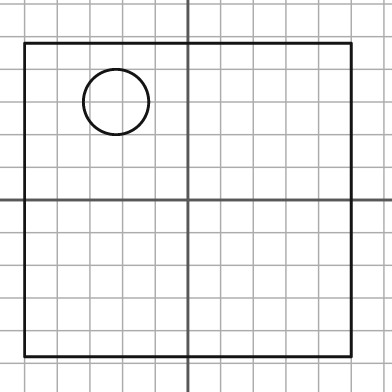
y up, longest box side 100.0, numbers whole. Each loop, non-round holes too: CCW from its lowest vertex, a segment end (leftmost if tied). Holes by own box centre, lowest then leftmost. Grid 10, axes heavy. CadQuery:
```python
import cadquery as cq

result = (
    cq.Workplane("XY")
    .moveTo(-50.0, -48.0)
    .lineTo(50.0, -48.0)
    .lineTo(50.0, 48.0)
    .lineTo(-50.0, 48.0)
    .close()
    .moveTo(-22.0, 30.0)
    .circle(10.0)
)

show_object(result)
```